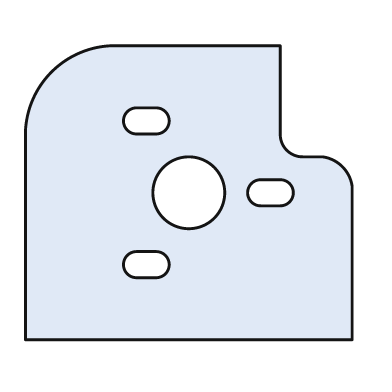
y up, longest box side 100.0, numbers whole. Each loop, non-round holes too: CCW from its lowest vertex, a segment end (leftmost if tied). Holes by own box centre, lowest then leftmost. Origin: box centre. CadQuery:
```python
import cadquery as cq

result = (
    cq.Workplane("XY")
    .moveTo(-50.0, -45.0)
    .lineTo(50.0, -45.0)
    .lineTo(50.0, 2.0)
    .threePointArc((47.0, 8.0), (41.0, 11.0))
    .lineTo(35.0, 11.0)
    .threePointArc((30.0, 13.0), (28.0, 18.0))
    .lineTo(28.0, 45.0)
    .lineTo(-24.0, 45.0)
    .threePointArc((-42.0, 37.0), (-50.0, 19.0))
    .close()
    .moveTo(-16.0, -26.0)
    .lineTo(-10.0, -26.0)
    .threePointArc((-6.0, -22.0), (-10.0, -18.0))
    .lineTo(-16.0, -18.0)
    .threePointArc((-20.0, -22.0), (-16.0, -26.0))
    .close()
    .moveTo(0.0, 0.0)
    .circle(11.0)
    .moveTo(22.0, -4.0)
    .lineTo(28.0, -4.0)
    .threePointArc((32.0, 0.0), (28.0, 4.0))
    .lineTo(22.0, 4.0)
    .threePointArc((18.0, 0.0), (22.0, -4.0))
    .close()
    .moveTo(-16.0, 18.0)
    .lineTo(-10.0, 18.0)
    .threePointArc((-6.0, 22.0), (-10.0, 26.0))
    .lineTo(-16.0, 26.0)
    .threePointArc((-20.0, 22.0), (-16.0, 18.0))
    .close()
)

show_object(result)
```